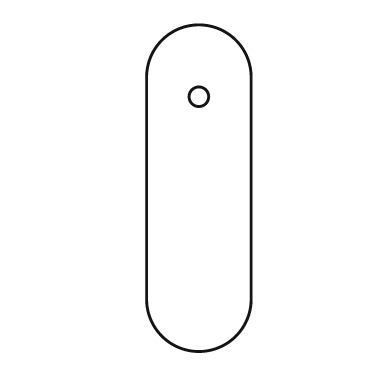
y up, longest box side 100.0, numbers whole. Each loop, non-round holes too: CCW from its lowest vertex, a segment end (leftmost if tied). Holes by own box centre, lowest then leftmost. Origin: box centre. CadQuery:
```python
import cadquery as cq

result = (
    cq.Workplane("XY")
    .moveTo(-16.0, -34.0)
    .threePointArc((0.0, -50.0), (16.0, -34.0))
    .lineTo(16.0, 34.0)
    .threePointArc((0.0, 50.0), (-16.0, 34.0))
    .close()
    .moveTo(0.0, 28.0)
    .circle(3.0)
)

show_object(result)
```